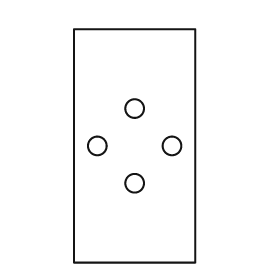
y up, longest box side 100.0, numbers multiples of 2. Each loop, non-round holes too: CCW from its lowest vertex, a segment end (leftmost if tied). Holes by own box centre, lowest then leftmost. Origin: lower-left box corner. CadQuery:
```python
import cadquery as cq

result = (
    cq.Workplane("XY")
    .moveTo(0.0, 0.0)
    .lineTo(52.0, 0.0)
    .lineTo(52.0, 100.0)
    .lineTo(0.0, 100.0)
    .close()
    .moveTo(26.0, 34.0)
    .circle(4.0)
    .moveTo(10.0, 50.0)
    .circle(4.0)
    .moveTo(42.0, 50.0)
    .circle(4.0)
    .moveTo(26.0, 66.0)
    .circle(4.0)
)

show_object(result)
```